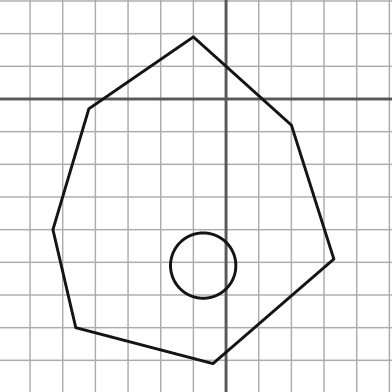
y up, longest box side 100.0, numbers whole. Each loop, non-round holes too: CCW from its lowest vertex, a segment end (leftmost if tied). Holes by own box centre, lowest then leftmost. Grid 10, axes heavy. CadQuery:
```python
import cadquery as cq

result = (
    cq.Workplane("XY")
    .moveTo(-4.0, -81.0)
    .lineTo(33.0, -49.0)
    .lineTo(20.0, -8.0)
    .lineTo(-10.0, 19.0)
    .lineTo(-42.0, -3.0)
    .lineTo(-53.0, -40.0)
    .lineTo(-46.0, -70.0)
    .close()
    .moveTo(-7.0, -51.0)
    .circle(10.0)
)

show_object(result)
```